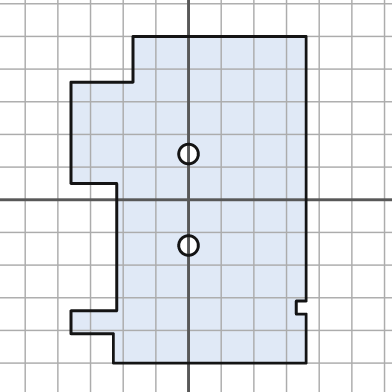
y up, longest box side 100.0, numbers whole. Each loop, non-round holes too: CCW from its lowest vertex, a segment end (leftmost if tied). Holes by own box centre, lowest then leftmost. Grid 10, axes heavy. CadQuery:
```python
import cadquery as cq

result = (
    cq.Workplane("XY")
    .moveTo(-23.0, -50.0)
    .lineTo(36.0, -50.0)
    .lineTo(36.0, -35.0)
    .lineTo(33.0, -35.0)
    .lineTo(33.0, -31.0)
    .lineTo(36.0, -31.0)
    .lineTo(36.0, 50.0)
    .lineTo(-17.0, 50.0)
    .lineTo(-17.0, 36.0)
    .lineTo(-36.0, 36.0)
    .lineTo(-36.0, 5.0)
    .lineTo(-22.0, 5.0)
    .lineTo(-22.0, -34.0)
    .lineTo(-36.0, -34.0)
    .lineTo(-36.0, -41.0)
    .lineTo(-23.0, -41.0)
    .close()
    .moveTo(0.0, -14.0)
    .circle(3.0)
    .moveTo(0.0, 14.0)
    .circle(3.0)
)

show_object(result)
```